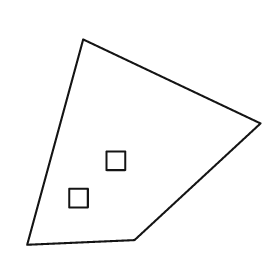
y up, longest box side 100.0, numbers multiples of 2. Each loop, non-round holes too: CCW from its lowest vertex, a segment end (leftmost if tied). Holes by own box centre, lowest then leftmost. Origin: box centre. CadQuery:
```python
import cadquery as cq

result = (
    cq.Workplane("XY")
    .moveTo(-50.0, -44.0)
    .lineTo(-4.0, -42.0)
    .lineTo(50.0, 8.0)
    .lineTo(-26.0, 44.0)
    .close()
    .moveTo(-32.0, -28.0)
    .lineTo(-24.0, -28.0)
    .lineTo(-24.0, -20.0)
    .lineTo(-32.0, -20.0)
    .close()
    .moveTo(-16.0, -12.0)
    .lineTo(-8.0, -12.0)
    .lineTo(-8.0, -4.0)
    .lineTo(-16.0, -4.0)
    .close()
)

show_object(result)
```